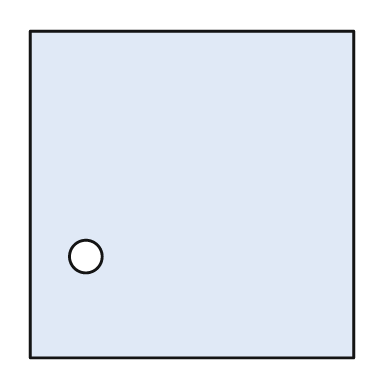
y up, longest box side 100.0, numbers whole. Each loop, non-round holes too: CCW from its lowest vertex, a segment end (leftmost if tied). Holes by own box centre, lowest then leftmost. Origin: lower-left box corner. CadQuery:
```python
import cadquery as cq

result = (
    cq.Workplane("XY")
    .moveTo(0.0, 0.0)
    .lineTo(99.0, 0.0)
    .lineTo(99.0, 100.0)
    .lineTo(0.0, 100.0)
    .close()
    .moveTo(17.0, 31.0)
    .circle(5.0)
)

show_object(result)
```